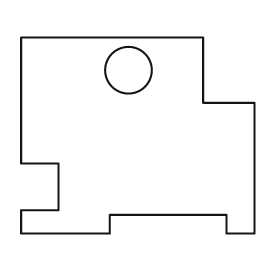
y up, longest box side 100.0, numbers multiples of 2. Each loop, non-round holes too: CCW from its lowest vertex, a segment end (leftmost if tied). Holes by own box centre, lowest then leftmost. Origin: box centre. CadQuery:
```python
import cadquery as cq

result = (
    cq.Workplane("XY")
    .moveTo(-50.0, -42.0)
    .lineTo(-12.0, -42.0)
    .lineTo(-12.0, -34.0)
    .lineTo(38.0, -34.0)
    .lineTo(38.0, -42.0)
    .lineTo(50.0, -42.0)
    .lineTo(50.0, 14.0)
    .lineTo(28.0, 14.0)
    .lineTo(28.0, 42.0)
    .lineTo(-50.0, 42.0)
    .lineTo(-50.0, -12.0)
    .lineTo(-34.0, -12.0)
    .lineTo(-34.0, -32.0)
    .lineTo(-50.0, -32.0)
    .close()
    .moveTo(-4.0, 28.0)
    .circle(10.0)
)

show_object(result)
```